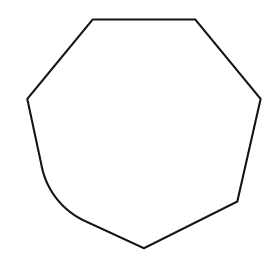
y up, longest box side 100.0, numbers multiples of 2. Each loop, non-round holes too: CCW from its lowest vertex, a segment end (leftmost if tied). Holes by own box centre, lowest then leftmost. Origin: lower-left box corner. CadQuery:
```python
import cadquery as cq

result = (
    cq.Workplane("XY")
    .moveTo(50.0, 0.0)
    .lineTo(90.0, 20.0)
    .lineTo(100.0, 64.0)
    .lineTo(72.0, 98.0)
    .lineTo(28.0, 98.0)
    .lineTo(0.0, 64.0)
    .lineTo(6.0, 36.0)
    .threePointArc((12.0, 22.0), (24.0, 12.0))
    .close()
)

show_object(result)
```